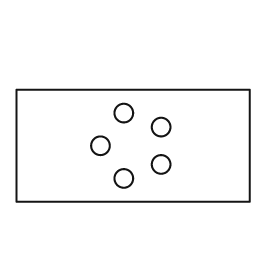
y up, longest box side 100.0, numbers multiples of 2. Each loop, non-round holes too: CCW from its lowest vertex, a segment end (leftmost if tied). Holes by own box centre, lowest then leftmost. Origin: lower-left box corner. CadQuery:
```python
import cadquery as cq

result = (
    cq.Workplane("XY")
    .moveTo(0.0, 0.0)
    .lineTo(100.0, 0.0)
    .lineTo(100.0, 48.0)
    .lineTo(0.0, 48.0)
    .close()
    .moveTo(46.0, 10.0)
    .circle(4.0)
    .moveTo(62.0, 16.0)
    .circle(4.0)
    .moveTo(36.0, 24.0)
    .circle(4.0)
    .moveTo(62.0, 32.0)
    .circle(4.0)
    .moveTo(46.0, 38.0)
    .circle(4.0)
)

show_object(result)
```